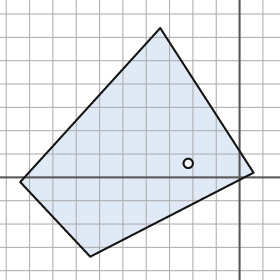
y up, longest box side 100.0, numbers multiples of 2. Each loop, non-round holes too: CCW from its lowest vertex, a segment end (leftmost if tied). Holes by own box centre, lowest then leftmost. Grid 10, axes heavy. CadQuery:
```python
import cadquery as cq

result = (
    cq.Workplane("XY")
    .moveTo(-64.0, -34.0)
    .lineTo(6.0, 2.0)
    .lineTo(-34.0, 64.0)
    .lineTo(-94.0, -2.0)
    .close()
    .moveTo(-22.0, 6.0)
    .circle(2.0)
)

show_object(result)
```